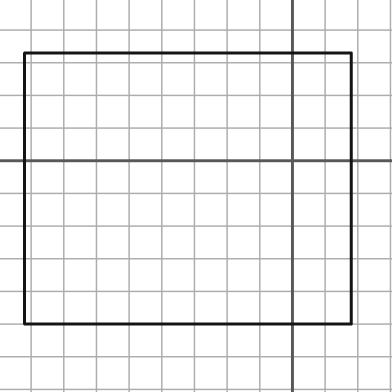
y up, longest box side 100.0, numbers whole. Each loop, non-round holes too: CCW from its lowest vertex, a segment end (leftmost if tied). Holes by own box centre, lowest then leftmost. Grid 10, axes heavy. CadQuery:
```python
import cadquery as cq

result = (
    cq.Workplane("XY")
    .moveTo(-82.0, -50.0)
    .lineTo(18.0, -50.0)
    .lineTo(18.0, 33.0)
    .lineTo(-82.0, 33.0)
    .close()
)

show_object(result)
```